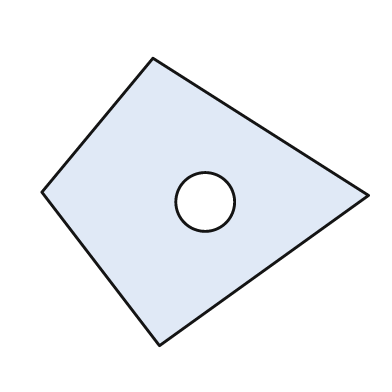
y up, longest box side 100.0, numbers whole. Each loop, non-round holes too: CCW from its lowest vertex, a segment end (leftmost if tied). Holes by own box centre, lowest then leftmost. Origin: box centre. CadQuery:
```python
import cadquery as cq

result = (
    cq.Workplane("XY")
    .moveTo(-14.0, -44.0)
    .lineTo(50.0, 2.0)
    .lineTo(-16.0, 44.0)
    .lineTo(-50.0, 3.0)
    .close()
    .moveTo(0.0, 0.0)
    .circle(9.0)
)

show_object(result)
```